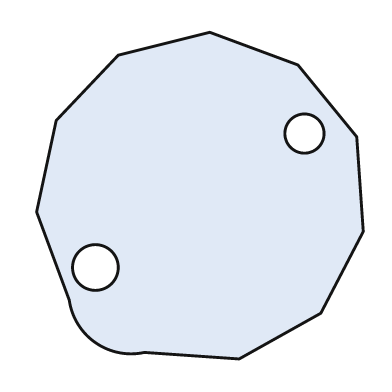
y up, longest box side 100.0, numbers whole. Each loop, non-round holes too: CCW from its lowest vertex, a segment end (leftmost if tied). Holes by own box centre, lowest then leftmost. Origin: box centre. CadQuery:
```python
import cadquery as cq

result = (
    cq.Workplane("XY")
    .moveTo(12.0, -50.0)
    .lineTo(37.0, -36.0)
    .lineTo(50.0, -11.0)
    .lineTo(48.0, 18.0)
    .lineTo(30.0, 40.0)
    .lineTo(3.0, 50.0)
    .lineTo(-25.0, 43.0)
    .lineTo(-44.0, 23.0)
    .lineTo(-50.0, -5.0)
    .lineTo(-40.0, -32.0)
    .threePointArc((-32.0, -45.0), (-17.0, -48.0))
    .close()
    .moveTo(-32.0, -22.0)
    .circle(7.0)
    .moveTo(32.0, 19.0)
    .circle(6.0)
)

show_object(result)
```